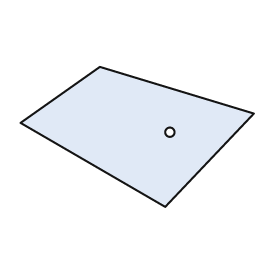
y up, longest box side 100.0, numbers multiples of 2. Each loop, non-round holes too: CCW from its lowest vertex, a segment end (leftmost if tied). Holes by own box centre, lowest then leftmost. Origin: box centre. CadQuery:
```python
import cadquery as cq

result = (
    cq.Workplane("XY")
    .moveTo(12.0, -30.0)
    .lineTo(50.0, 10.0)
    .lineTo(-16.0, 30.0)
    .lineTo(-50.0, 6.0)
    .close()
    .moveTo(14.0, 2.0)
    .circle(2.0)
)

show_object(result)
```